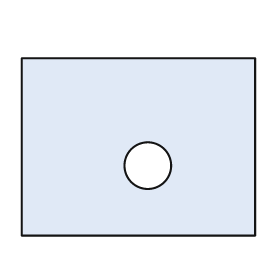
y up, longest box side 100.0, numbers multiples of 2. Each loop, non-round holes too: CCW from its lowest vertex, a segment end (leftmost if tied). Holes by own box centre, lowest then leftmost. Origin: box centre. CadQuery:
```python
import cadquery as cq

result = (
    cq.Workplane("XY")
    .moveTo(-50.0, -38.0)
    .lineTo(50.0, -38.0)
    .lineTo(50.0, 38.0)
    .lineTo(-50.0, 38.0)
    .close()
    .moveTo(4.0, -8.0)
    .circle(10.0)
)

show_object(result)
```